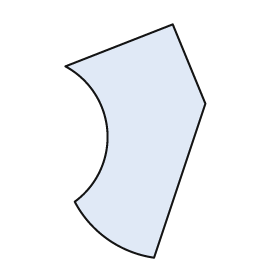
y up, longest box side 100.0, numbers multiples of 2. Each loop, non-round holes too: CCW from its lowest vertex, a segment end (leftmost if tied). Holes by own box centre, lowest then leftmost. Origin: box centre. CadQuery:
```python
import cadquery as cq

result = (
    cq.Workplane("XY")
    .moveTo(8.0, -50.0)
    .lineTo(30.0, 16.0)
    .lineTo(16.0, 50.0)
    .lineTo(-30.0, 32.0)
    .threePointArc((-12.0, 4.0), (-26.0, -26.0))
    .threePointArc((-12.0, -42.0), (8.0, -50.0))
    .close()
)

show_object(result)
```